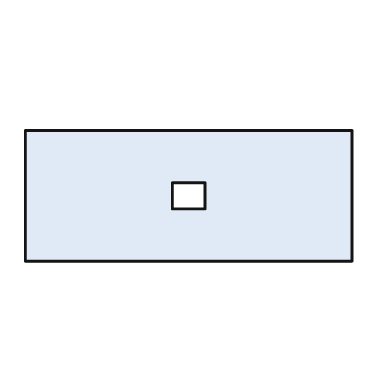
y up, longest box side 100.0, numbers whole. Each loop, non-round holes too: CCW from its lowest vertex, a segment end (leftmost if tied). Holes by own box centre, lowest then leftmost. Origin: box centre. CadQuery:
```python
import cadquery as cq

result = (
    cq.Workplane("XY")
    .moveTo(-50.0, -20.0)
    .lineTo(50.0, -20.0)
    .lineTo(50.0, 20.0)
    .lineTo(-50.0, 20.0)
    .close()
    .moveTo(-5.0, -4.0)
    .lineTo(5.0, -4.0)
    .lineTo(5.0, 4.0)
    .lineTo(-5.0, 4.0)
    .close()
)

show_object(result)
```